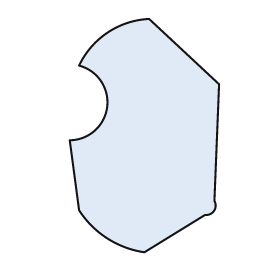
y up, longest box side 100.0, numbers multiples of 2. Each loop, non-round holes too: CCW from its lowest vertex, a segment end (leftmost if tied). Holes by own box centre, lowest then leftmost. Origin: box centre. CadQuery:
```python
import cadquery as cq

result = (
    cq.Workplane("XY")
    .moveTo(0.0, -50.0)
    .lineTo(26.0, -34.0)
    .threePointArc((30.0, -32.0), (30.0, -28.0))
    .lineTo(32.0, 22.0)
    .lineTo(2.0, 50.0)
    .threePointArc((-16.0, 44.0), (-28.0, 30.0))
    .threePointArc((-16.0, 12.0), (-32.0, -2.0))
    .lineTo(-28.0, -32.0)
    .threePointArc((-16.0, -44.0), (0.0, -50.0))
    .close()
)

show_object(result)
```